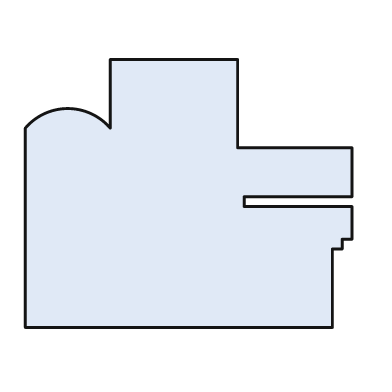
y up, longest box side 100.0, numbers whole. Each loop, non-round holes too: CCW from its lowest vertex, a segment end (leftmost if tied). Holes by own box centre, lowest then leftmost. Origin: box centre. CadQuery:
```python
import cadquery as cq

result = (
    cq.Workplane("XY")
    .moveTo(-50.0, -41.0)
    .lineTo(44.0, -41.0)
    .lineTo(44.0, -17.0)
    .lineTo(47.0, -17.0)
    .lineTo(47.0, -14.0)
    .lineTo(50.0, -14.0)
    .lineTo(50.0, -4.0)
    .lineTo(17.0, -4.0)
    .lineTo(17.0, -1.0)
    .lineTo(50.0, -1.0)
    .lineTo(50.0, 14.0)
    .lineTo(15.0, 14.0)
    .lineTo(15.0, 41.0)
    .lineTo(-24.0, 41.0)
    .lineTo(-24.0, 20.0)
    .threePointArc((-37.0, 26.0), (-50.0, 20.0))
    .close()
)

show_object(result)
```